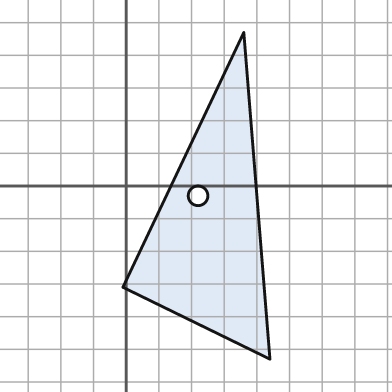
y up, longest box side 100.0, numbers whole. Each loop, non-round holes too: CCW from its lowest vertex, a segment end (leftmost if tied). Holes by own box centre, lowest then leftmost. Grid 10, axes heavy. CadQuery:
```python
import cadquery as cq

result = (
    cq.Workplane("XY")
    .moveTo(44.0, -53.0)
    .lineTo(36.0, 47.0)
    .lineTo(-1.0, -31.0)
    .close()
    .moveTo(22.0, -3.0)
    .circle(3.0)
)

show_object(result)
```